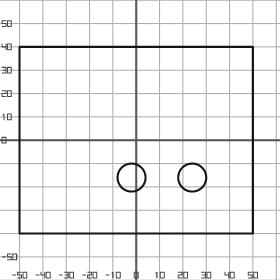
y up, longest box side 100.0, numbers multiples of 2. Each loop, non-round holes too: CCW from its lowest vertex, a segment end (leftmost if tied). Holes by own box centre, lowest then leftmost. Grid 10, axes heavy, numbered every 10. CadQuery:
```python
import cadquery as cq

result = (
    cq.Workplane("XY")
    .moveTo(-50.0, -40.0)
    .lineTo(50.0, -40.0)
    .lineTo(50.0, 40.0)
    .lineTo(-50.0, 40.0)
    .close()
    .moveTo(-2.0, -16.0)
    .circle(6.0)
    .moveTo(24.0, -16.0)
    .circle(6.0)
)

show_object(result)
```